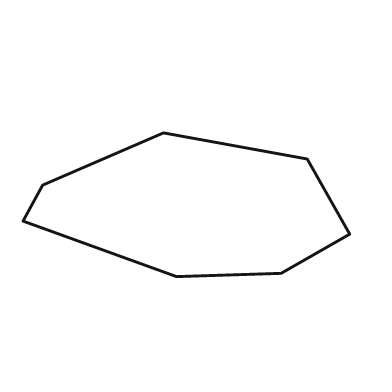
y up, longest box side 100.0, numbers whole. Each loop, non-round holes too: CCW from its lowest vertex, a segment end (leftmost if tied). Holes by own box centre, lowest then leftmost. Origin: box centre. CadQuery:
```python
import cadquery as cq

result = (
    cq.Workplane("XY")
    .moveTo(-3.0, -22.0)
    .lineTo(29.0, -21.0)
    .lineTo(50.0, -9.0)
    .lineTo(37.0, 14.0)
    .lineTo(-7.0, 22.0)
    .lineTo(-44.0, 6.0)
    .lineTo(-50.0, -5.0)
    .close()
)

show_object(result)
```